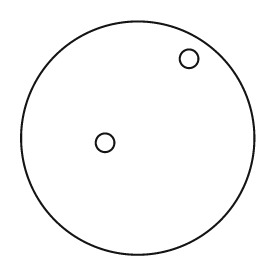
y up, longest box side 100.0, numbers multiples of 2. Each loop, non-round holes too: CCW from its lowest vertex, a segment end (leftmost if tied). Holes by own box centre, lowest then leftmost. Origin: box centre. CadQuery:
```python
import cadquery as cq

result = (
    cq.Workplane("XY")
    .moveTo(0.0, 0.0)
    .circle(50.0)
    .moveTo(-14.0, -2.0)
    .circle(4.0)
    .moveTo(22.0, 34.0)
    .circle(4.0)
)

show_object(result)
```